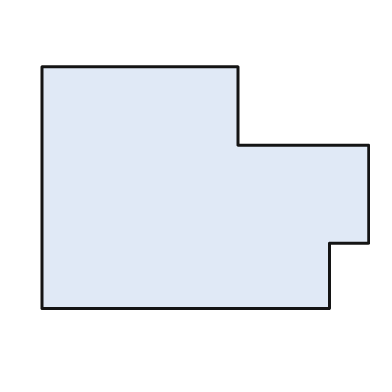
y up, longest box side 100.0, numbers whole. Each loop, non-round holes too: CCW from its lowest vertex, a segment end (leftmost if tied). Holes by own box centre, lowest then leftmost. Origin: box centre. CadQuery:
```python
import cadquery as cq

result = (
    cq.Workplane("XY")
    .moveTo(-50.0, -37.0)
    .lineTo(38.0, -37.0)
    .lineTo(38.0, -17.0)
    .lineTo(50.0, -17.0)
    .lineTo(50.0, 13.0)
    .lineTo(10.0, 13.0)
    .lineTo(10.0, 37.0)
    .lineTo(-50.0, 37.0)
    .close()
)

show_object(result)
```